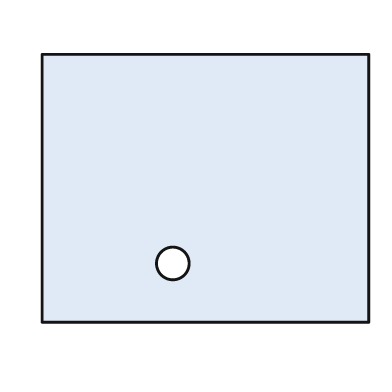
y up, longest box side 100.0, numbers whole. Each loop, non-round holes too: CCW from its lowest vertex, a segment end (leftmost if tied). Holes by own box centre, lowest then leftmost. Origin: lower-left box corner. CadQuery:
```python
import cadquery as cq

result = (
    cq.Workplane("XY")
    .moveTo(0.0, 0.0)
    .lineTo(100.0, 0.0)
    .lineTo(100.0, 82.0)
    .lineTo(0.0, 82.0)
    .close()
    .moveTo(40.0, 18.0)
    .circle(5.0)
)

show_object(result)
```